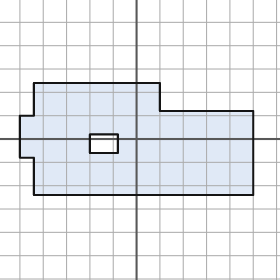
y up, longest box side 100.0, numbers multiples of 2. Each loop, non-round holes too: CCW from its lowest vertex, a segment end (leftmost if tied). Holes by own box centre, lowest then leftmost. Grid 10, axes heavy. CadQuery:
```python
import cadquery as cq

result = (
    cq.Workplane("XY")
    .moveTo(-44.0, -24.0)
    .lineTo(50.0, -24.0)
    .lineTo(50.0, 12.0)
    .lineTo(10.0, 12.0)
    .lineTo(10.0, 24.0)
    .lineTo(-44.0, 24.0)
    .lineTo(-44.0, 10.0)
    .lineTo(-50.0, 10.0)
    .lineTo(-50.0, -8.0)
    .lineTo(-44.0, -8.0)
    .close()
    .moveTo(-20.0, -6.0)
    .lineTo(-8.0, -6.0)
    .lineTo(-8.0, 2.0)
    .lineTo(-20.0, 2.0)
    .close()
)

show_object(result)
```